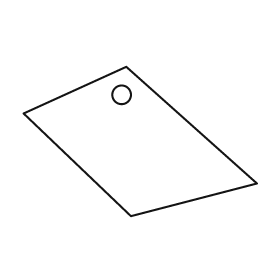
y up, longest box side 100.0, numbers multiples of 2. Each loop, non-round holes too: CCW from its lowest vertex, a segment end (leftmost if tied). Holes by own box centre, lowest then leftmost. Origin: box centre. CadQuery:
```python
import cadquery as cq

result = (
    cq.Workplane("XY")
    .moveTo(-4.0, -32.0)
    .lineTo(50.0, -18.0)
    .lineTo(-6.0, 32.0)
    .lineTo(-50.0, 12.0)
    .close()
    .moveTo(-8.0, 20.0)
    .circle(4.0)
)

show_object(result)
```